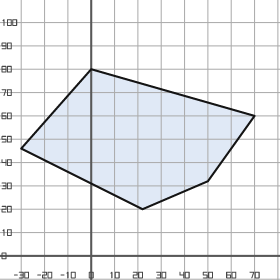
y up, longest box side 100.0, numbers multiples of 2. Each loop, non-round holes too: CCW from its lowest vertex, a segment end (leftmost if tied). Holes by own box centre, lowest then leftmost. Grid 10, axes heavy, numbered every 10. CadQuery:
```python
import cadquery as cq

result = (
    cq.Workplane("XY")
    .moveTo(22.0, 20.0)
    .lineTo(50.0, 32.0)
    .lineTo(70.0, 60.0)
    .lineTo(0.0, 80.0)
    .lineTo(-30.0, 46.0)
    .close()
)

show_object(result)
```